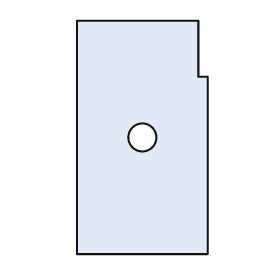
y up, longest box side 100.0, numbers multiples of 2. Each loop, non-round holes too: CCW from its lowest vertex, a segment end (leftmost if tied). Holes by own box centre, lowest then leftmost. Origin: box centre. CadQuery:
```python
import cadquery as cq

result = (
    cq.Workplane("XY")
    .moveTo(-28.0, -50.0)
    .lineTo(28.0, -50.0)
    .lineTo(28.0, 26.0)
    .lineTo(24.0, 26.0)
    .lineTo(24.0, 50.0)
    .lineTo(-28.0, 50.0)
    .close()
    .moveTo(0.0, 0.0)
    .circle(6.0)
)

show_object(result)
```